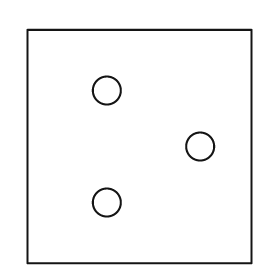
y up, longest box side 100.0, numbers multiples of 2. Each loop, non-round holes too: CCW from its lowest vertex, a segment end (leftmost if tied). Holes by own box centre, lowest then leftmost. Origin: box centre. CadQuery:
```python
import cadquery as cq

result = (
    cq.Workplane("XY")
    .moveTo(-48.0, -50.0)
    .lineTo(48.0, -50.0)
    .lineTo(48.0, 50.0)
    .lineTo(-48.0, 50.0)
    .close()
    .moveTo(-14.0, -24.0)
    .circle(6.0)
    .moveTo(26.0, 0.0)
    .circle(6.0)
    .moveTo(-14.0, 24.0)
    .circle(6.0)
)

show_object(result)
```